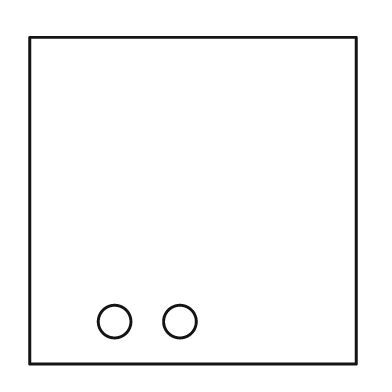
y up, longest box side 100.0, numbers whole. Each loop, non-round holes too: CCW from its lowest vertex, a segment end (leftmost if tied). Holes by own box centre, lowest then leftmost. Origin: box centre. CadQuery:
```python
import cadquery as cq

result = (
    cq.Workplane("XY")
    .moveTo(-50.0, -50.0)
    .lineTo(50.0, -50.0)
    .lineTo(50.0, 50.0)
    .lineTo(-50.0, 50.0)
    .close()
    .moveTo(-24.0, -37.0)
    .circle(5.0)
    .moveTo(-4.0, -37.0)
    .circle(5.0)
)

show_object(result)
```